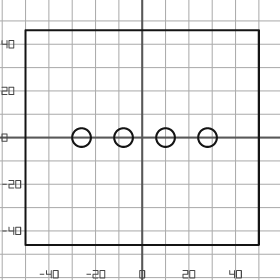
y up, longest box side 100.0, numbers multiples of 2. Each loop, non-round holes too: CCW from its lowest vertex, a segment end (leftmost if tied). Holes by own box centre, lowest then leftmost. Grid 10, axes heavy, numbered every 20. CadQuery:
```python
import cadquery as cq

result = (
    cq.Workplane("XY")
    .moveTo(-50.0, -46.0)
    .lineTo(50.0, -46.0)
    .lineTo(50.0, 46.0)
    .lineTo(-50.0, 46.0)
    .close()
    .moveTo(-26.0, 0.0)
    .circle(4.0)
    .moveTo(-8.0, 0.0)
    .circle(4.0)
    .moveTo(10.0, 0.0)
    .circle(4.0)
    .moveTo(28.0, 0.0)
    .circle(4.0)
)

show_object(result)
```